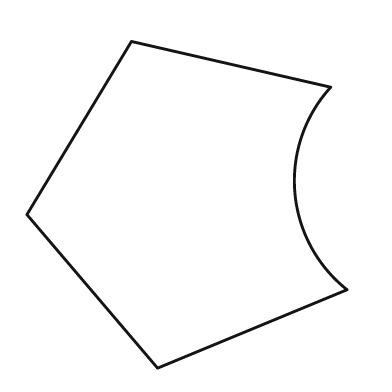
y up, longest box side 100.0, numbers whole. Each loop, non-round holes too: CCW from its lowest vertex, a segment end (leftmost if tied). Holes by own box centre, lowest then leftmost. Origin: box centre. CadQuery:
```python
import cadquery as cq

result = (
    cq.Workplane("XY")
    .moveTo(-9.0, -50.0)
    .lineTo(49.0, -26.0)
    .threePointArc((33.0, 4.0), (44.0, 36.0))
    .lineTo(-17.0, 50.0)
    .lineTo(-49.0, -3.0)
    .close()
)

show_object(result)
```